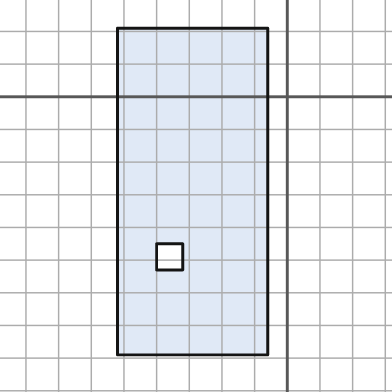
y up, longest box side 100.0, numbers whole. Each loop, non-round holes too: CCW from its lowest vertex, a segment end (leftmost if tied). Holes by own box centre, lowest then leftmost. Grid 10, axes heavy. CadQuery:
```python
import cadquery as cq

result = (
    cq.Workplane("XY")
    .moveTo(-52.0, -79.0)
    .lineTo(-6.0, -79.0)
    .lineTo(-6.0, 21.0)
    .lineTo(-52.0, 21.0)
    .close()
    .moveTo(-40.0, -53.0)
    .lineTo(-32.0, -53.0)
    .lineTo(-32.0, -45.0)
    .lineTo(-40.0, -45.0)
    .close()
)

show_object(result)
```